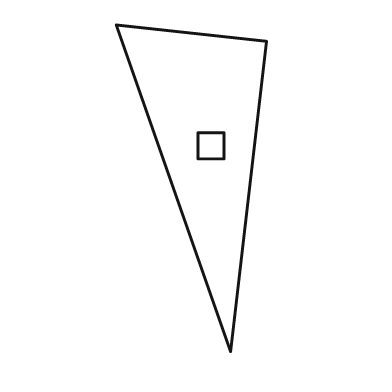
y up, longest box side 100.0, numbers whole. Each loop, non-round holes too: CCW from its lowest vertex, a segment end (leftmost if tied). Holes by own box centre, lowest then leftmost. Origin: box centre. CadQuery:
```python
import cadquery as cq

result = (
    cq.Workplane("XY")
    .moveTo(12.0, -50.0)
    .lineTo(23.0, 45.0)
    .lineTo(-23.0, 50.0)
    .close()
    .moveTo(2.0, 9.0)
    .lineTo(10.0, 9.0)
    .lineTo(10.0, 17.0)
    .lineTo(2.0, 17.0)
    .close()
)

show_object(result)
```